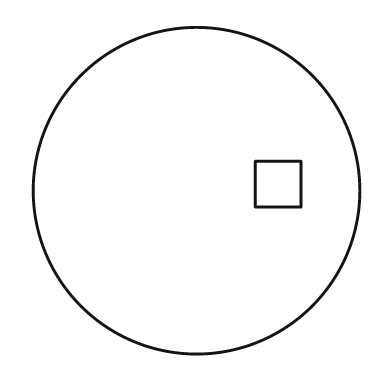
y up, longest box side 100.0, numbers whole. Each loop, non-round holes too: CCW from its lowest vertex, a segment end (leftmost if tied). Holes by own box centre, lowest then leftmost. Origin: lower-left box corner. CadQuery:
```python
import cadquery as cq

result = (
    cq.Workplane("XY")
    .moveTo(50.0, 50.0)
    .circle(50.0)
    .moveTo(68.0, 45.0)
    .lineTo(82.0, 45.0)
    .lineTo(82.0, 59.0)
    .lineTo(68.0, 59.0)
    .close()
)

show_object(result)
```